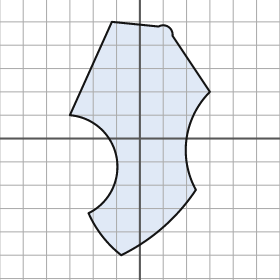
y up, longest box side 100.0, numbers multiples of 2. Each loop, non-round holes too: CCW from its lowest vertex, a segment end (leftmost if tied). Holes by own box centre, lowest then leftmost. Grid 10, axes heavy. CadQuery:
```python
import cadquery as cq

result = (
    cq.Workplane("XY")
    .moveTo(-8.0, -50.0)
    .threePointArc((10.0, -38.0), (24.0, -22.0))
    .threePointArc((20.0, 0.0), (30.0, 20.0))
    .lineTo(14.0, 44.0)
    .threePointArc((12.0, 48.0), (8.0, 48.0))
    .lineTo(-12.0, 50.0)
    .lineTo(-30.0, 10.0)
    .threePointArc((-10.0, -8.0), (-22.0, -32.0))
    .threePointArc((-16.0, -42.0), (-8.0, -50.0))
    .close()
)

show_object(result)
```